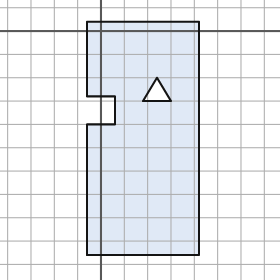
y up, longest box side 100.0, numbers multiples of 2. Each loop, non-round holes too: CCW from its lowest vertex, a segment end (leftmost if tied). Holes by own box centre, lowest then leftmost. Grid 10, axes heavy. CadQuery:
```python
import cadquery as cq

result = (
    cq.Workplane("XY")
    .moveTo(-6.0, -96.0)
    .lineTo(42.0, -96.0)
    .lineTo(42.0, 4.0)
    .lineTo(-6.0, 4.0)
    .lineTo(-6.0, -28.0)
    .lineTo(6.0, -28.0)
    .lineTo(6.0, -40.0)
    .lineTo(-6.0, -40.0)
    .close()
    .moveTo(18.0, -30.0)
    .lineTo(30.0, -30.0)
    .lineTo(24.0, -20.0)
    .close()
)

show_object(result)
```